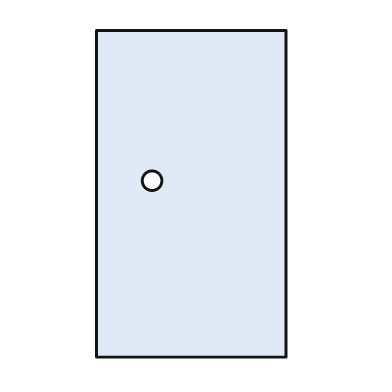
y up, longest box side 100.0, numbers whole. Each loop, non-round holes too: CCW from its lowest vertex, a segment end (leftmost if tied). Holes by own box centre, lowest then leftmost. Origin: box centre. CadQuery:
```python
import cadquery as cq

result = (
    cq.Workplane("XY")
    .moveTo(-29.0, -50.0)
    .lineTo(29.0, -50.0)
    .lineTo(29.0, 50.0)
    .lineTo(-29.0, 50.0)
    .close()
    .moveTo(-12.0, 4.0)
    .circle(3.0)
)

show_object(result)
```